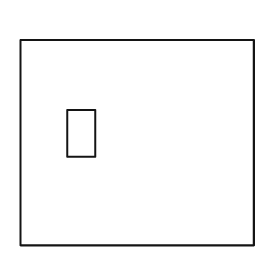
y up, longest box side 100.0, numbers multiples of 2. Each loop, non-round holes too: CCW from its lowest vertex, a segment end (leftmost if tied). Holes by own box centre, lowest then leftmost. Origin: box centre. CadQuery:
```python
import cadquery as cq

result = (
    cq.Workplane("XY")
    .moveTo(-50.0, -44.0)
    .lineTo(50.0, -44.0)
    .lineTo(50.0, 44.0)
    .lineTo(-50.0, 44.0)
    .close()
    .moveTo(-30.0, -6.0)
    .lineTo(-18.0, -6.0)
    .lineTo(-18.0, 14.0)
    .lineTo(-30.0, 14.0)
    .close()
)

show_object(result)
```